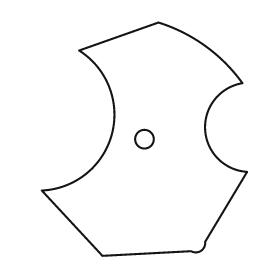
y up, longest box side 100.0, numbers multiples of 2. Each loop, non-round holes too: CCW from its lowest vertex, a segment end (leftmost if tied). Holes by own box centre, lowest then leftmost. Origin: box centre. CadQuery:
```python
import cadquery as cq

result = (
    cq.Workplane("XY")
    .moveTo(-18.0, -50.0)
    .lineTo(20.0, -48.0)
    .threePointArc((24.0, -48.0), (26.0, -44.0))
    .lineTo(44.0, -14.0)
    .threePointArc((26.0, 4.0), (42.0, 24.0))
    .threePointArc((26.0, 40.0), (6.0, 50.0))
    .lineTo(-28.0, 38.0)
    .threePointArc((-14.0, 2.0), (-44.0, -22.0))
    .close()
    .moveTo(0.0, 0.0)
    .circle(4.0)
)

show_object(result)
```